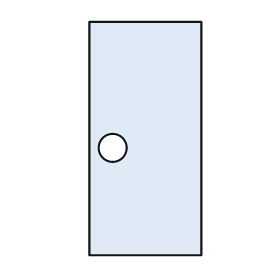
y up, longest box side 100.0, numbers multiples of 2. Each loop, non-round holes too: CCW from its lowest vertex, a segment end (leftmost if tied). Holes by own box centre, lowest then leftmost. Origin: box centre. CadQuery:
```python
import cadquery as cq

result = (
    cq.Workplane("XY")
    .moveTo(-24.0, -50.0)
    .lineTo(24.0, -50.0)
    .lineTo(24.0, 50.0)
    .lineTo(-24.0, 50.0)
    .close()
    .moveTo(-14.0, -4.0)
    .circle(6.0)
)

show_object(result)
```